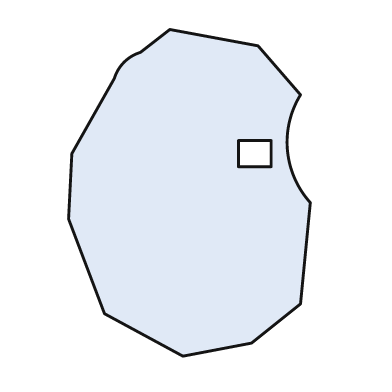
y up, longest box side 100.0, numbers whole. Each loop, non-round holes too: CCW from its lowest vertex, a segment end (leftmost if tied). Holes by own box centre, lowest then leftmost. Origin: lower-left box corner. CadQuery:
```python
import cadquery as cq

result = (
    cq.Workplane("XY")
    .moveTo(35.0, 0.0)
    .lineTo(56.0, 4.0)
    .lineTo(71.0, 16.0)
    .lineTo(74.0, 47.0)
    .threePointArc((67.0, 63.0), (71.0, 80.0))
    .lineTo(58.0, 95.0)
    .lineTo(31.0, 100.0)
    .lineTo(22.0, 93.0)
    .threePointArc((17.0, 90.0), (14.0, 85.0))
    .lineTo(1.0, 62.0)
    .lineTo(0.0, 42.0)
    .lineTo(11.0, 13.0)
    .close()
    .moveTo(52.0, 58.0)
    .lineTo(62.0, 58.0)
    .lineTo(62.0, 66.0)
    .lineTo(52.0, 66.0)
    .close()
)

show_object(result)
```